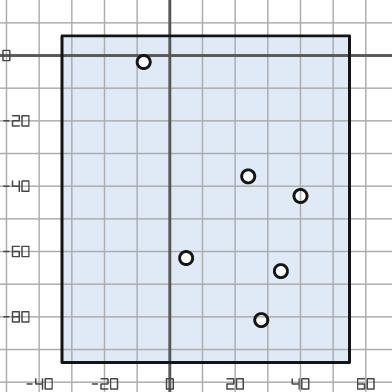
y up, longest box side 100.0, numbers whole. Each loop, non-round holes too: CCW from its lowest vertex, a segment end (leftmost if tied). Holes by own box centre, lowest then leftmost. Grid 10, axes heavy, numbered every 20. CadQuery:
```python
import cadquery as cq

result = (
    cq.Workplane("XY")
    .moveTo(-33.0, -94.0)
    .lineTo(55.0, -94.0)
    .lineTo(55.0, 6.0)
    .lineTo(-33.0, 6.0)
    .close()
    .moveTo(28.0, -81.0)
    .circle(2.0)
    .moveTo(34.0, -66.0)
    .circle(2.0)
    .moveTo(5.0, -62.0)
    .circle(2.0)
    .moveTo(40.0, -43.0)
    .circle(2.0)
    .moveTo(24.0, -37.0)
    .circle(2.0)
    .moveTo(-8.0, -2.0)
    .circle(2.0)
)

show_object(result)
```